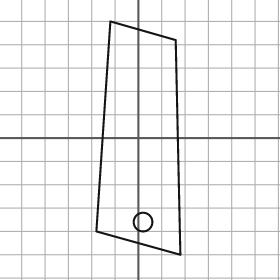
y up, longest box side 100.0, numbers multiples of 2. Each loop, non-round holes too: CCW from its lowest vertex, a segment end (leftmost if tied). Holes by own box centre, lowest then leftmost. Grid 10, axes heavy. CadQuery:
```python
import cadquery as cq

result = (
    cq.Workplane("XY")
    .moveTo(18.0, -50.0)
    .lineTo(16.0, 42.0)
    .lineTo(-12.0, 50.0)
    .lineTo(-18.0, -40.0)
    .close()
    .moveTo(2.0, -36.0)
    .circle(4.0)
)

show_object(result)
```